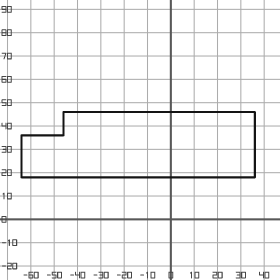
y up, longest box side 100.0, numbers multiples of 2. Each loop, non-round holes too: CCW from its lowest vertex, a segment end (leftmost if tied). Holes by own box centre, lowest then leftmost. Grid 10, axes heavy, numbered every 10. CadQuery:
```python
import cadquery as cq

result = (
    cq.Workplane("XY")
    .moveTo(-64.0, 18.0)
    .lineTo(36.0, 18.0)
    .lineTo(36.0, 46.0)
    .lineTo(-46.0, 46.0)
    .lineTo(-46.0, 36.0)
    .lineTo(-64.0, 36.0)
    .close()
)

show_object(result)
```